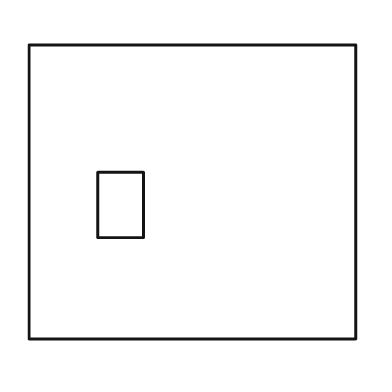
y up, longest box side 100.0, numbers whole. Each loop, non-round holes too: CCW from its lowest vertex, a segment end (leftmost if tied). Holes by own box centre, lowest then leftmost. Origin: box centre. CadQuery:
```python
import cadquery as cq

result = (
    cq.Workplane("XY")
    .moveTo(-50.0, -45.0)
    .lineTo(50.0, -45.0)
    .lineTo(50.0, 45.0)
    .lineTo(-50.0, 45.0)
    .close()
    .moveTo(-29.0, -14.0)
    .lineTo(-15.0, -14.0)
    .lineTo(-15.0, 6.0)
    .lineTo(-29.0, 6.0)
    .close()
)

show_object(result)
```